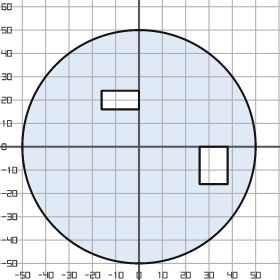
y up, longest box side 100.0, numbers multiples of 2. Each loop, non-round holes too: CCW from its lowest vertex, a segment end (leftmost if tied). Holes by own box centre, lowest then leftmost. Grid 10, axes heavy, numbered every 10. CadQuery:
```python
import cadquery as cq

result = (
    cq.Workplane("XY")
    .moveTo(0.0, 0.0)
    .circle(50.0)
    .moveTo(26.0, -16.0)
    .lineTo(38.0, -16.0)
    .lineTo(38.0, 0.0)
    .lineTo(26.0, 0.0)
    .close()
    .moveTo(-16.0, 16.0)
    .lineTo(0.0, 16.0)
    .lineTo(0.0, 24.0)
    .lineTo(-16.0, 24.0)
    .close()
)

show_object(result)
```